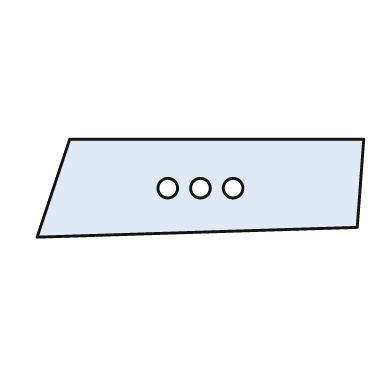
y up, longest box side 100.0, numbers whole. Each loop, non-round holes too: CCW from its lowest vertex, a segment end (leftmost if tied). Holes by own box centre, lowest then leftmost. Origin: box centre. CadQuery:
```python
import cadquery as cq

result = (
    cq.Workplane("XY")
    .moveTo(-50.0, -15.0)
    .lineTo(48.0, -12.0)
    .lineTo(50.0, 15.0)
    .lineTo(-40.0, 15.0)
    .close()
    .moveTo(-10.0, 0.0)
    .circle(3.0)
    .moveTo(0.0, 0.0)
    .circle(3.0)
    .moveTo(10.0, 0.0)
    .circle(3.0)
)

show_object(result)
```